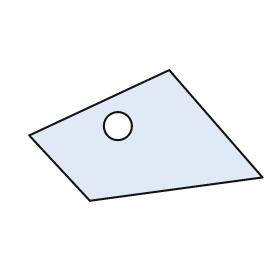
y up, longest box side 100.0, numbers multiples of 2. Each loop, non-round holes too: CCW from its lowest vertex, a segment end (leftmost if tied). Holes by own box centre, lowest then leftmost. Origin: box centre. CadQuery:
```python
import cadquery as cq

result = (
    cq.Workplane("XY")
    .moveTo(-24.0, -28.0)
    .lineTo(50.0, -18.0)
    .lineTo(10.0, 28.0)
    .lineTo(-50.0, 0.0)
    .close()
    .moveTo(-12.0, 4.0)
    .circle(6.0)
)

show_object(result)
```